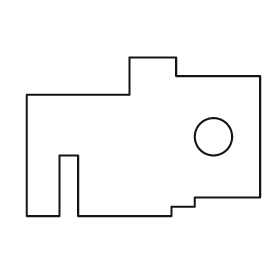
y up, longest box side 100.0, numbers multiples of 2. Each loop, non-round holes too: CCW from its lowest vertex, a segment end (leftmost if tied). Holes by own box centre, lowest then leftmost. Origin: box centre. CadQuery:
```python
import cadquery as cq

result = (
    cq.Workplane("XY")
    .moveTo(-50.0, -34.0)
    .lineTo(-36.0, -34.0)
    .lineTo(-36.0, -8.0)
    .lineTo(-28.0, -8.0)
    .lineTo(-28.0, -34.0)
    .lineTo(12.0, -34.0)
    .lineTo(12.0, -30.0)
    .lineTo(22.0, -30.0)
    .lineTo(22.0, -26.0)
    .lineTo(50.0, -26.0)
    .lineTo(50.0, 26.0)
    .lineTo(14.0, 26.0)
    .lineTo(14.0, 34.0)
    .lineTo(-6.0, 34.0)
    .lineTo(-6.0, 18.0)
    .lineTo(-50.0, 18.0)
    .close()
    .moveTo(30.0, 0.0)
    .circle(8.0)
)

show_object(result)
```